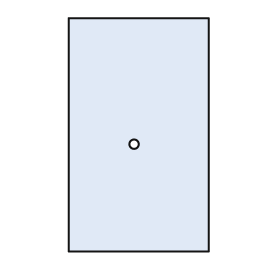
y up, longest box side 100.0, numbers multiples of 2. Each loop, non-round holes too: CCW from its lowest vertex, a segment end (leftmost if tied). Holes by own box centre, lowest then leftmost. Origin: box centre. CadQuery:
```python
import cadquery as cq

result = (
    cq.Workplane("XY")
    .moveTo(-30.0, -50.0)
    .lineTo(30.0, -50.0)
    .lineTo(30.0, 50.0)
    .lineTo(-30.0, 50.0)
    .close()
    .moveTo(-2.0, -4.0)
    .circle(2.0)
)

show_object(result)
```